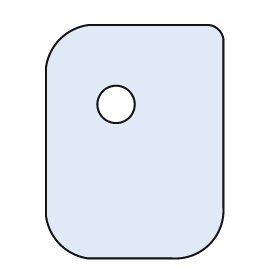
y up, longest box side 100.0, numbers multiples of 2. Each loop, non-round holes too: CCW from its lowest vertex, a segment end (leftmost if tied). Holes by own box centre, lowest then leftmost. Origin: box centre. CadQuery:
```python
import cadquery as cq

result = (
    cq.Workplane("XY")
    .moveTo(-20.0, -50.0)
    .lineTo(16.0, -50.0)
    .threePointArc((32.0, -44.0), (38.0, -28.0))
    .lineTo(38.0, 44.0)
    .threePointArc((36.0, 48.0), (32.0, 50.0))
    .lineTo(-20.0, 50.0)
    .threePointArc((-32.0, 44.0), (-38.0, 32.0))
    .lineTo(-38.0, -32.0)
    .threePointArc((-32.0, -44.0), (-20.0, -50.0))
    .close()
    .moveTo(-8.0, 16.0)
    .circle(8.0)
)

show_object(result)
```